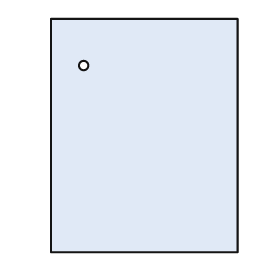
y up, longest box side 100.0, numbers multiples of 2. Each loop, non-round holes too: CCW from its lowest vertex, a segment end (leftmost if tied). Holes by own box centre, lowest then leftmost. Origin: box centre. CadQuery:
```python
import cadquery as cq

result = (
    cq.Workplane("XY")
    .moveTo(-40.0, -50.0)
    .lineTo(40.0, -50.0)
    .lineTo(40.0, 50.0)
    .lineTo(-40.0, 50.0)
    .close()
    .moveTo(-26.0, 30.0)
    .circle(2.0)
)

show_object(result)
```